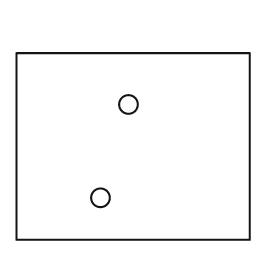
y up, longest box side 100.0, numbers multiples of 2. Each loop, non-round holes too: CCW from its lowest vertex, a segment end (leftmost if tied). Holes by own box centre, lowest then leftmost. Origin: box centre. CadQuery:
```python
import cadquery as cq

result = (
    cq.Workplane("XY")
    .moveTo(-50.0, -40.0)
    .lineTo(50.0, -40.0)
    .lineTo(50.0, 40.0)
    .lineTo(-50.0, 40.0)
    .close()
    .moveTo(-14.0, -22.0)
    .circle(4.0)
    .moveTo(-2.0, 18.0)
    .circle(4.0)
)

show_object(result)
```